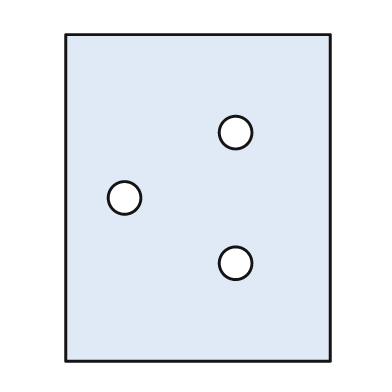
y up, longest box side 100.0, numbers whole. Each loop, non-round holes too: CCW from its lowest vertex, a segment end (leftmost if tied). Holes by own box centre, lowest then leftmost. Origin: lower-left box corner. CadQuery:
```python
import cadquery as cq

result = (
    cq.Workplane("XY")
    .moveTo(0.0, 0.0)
    .lineTo(81.0, 0.0)
    .lineTo(81.0, 100.0)
    .lineTo(0.0, 100.0)
    .close()
    .moveTo(52.0, 30.0)
    .circle(5.0)
    .moveTo(18.0, 50.0)
    .circle(5.0)
    .moveTo(52.0, 70.0)
    .circle(5.0)
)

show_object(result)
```